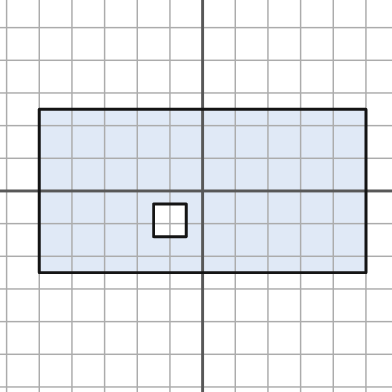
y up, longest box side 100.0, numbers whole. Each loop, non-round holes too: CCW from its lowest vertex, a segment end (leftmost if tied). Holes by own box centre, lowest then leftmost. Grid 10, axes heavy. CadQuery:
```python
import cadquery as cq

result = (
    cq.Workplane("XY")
    .moveTo(-50.0, -25.0)
    .lineTo(50.0, -25.0)
    .lineTo(50.0, 25.0)
    .lineTo(-50.0, 25.0)
    .close()
    .moveTo(-15.0, -14.0)
    .lineTo(-5.0, -14.0)
    .lineTo(-5.0, -4.0)
    .lineTo(-15.0, -4.0)
    .close()
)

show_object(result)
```